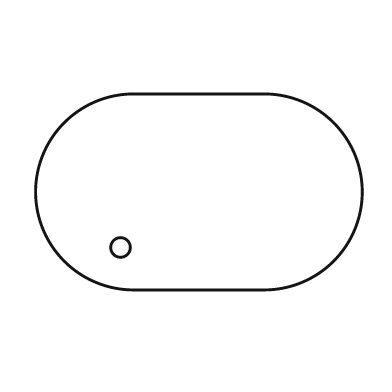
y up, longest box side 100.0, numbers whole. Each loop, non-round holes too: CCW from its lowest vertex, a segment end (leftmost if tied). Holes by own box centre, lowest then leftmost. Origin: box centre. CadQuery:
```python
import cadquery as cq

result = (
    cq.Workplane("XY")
    .moveTo(-20.0, -30.0)
    .lineTo(20.0, -30.0)
    .threePointArc((50.0, 0.0), (20.0, 30.0))
    .lineTo(-20.0, 30.0)
    .threePointArc((-50.0, 0.0), (-20.0, -30.0))
    .close()
    .moveTo(-24.0, -17.0)
    .circle(3.0)
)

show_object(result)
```